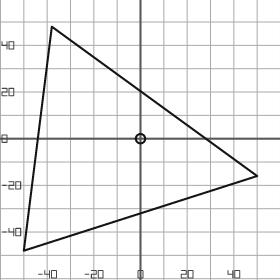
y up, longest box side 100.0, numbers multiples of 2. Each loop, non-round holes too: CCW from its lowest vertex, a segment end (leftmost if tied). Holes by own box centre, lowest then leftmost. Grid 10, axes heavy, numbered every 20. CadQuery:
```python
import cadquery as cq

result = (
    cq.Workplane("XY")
    .moveTo(-50.0, -48.0)
    .lineTo(50.0, -16.0)
    .lineTo(-38.0, 48.0)
    .close()
    .moveTo(0.0, 0.0)
    .circle(2.0)
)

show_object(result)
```